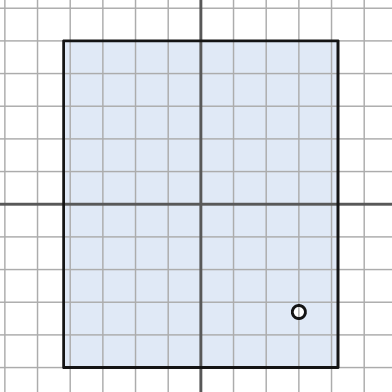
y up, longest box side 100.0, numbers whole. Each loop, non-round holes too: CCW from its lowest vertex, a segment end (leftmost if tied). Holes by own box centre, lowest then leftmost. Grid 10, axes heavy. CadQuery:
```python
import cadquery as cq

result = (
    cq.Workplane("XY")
    .moveTo(-42.0, -50.0)
    .lineTo(42.0, -50.0)
    .lineTo(42.0, 50.0)
    .lineTo(-42.0, 50.0)
    .close()
    .moveTo(30.0, -33.0)
    .circle(2.0)
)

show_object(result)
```